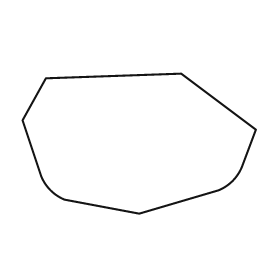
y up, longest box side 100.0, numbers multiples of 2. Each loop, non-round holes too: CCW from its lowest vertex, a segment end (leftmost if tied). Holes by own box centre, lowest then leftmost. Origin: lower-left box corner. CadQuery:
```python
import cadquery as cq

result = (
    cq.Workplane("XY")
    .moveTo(50.0, 0.0)
    .lineTo(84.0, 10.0)
    .threePointArc((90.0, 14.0), (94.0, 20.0))
    .lineTo(100.0, 36.0)
    .lineTo(68.0, 60.0)
    .lineTo(10.0, 58.0)
    .lineTo(0.0, 40.0)
    .lineTo(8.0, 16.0)
    .threePointArc((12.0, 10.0), (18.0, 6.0))
    .close()
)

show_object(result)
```